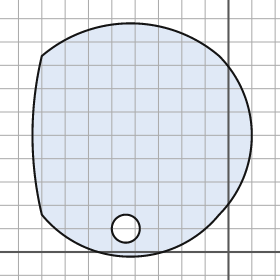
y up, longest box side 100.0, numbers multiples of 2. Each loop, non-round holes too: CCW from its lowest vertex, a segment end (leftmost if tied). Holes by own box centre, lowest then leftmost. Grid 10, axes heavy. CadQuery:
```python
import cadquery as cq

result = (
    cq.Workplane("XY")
    .moveTo(-80.0, 16.0)
    .threePointArc((-42.0, -2.0), (-4.0, 16.0))
    .threePointArc((10.0, 50.0), (-4.0, 84.0))
    .threePointArc((-42.0, 98.0), (-80.0, 84.0))
    .threePointArc((-84.0, 50.0), (-80.0, 16.0))
    .close()
    .moveTo(-44.0, 10.0)
    .circle(6.0)
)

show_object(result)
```